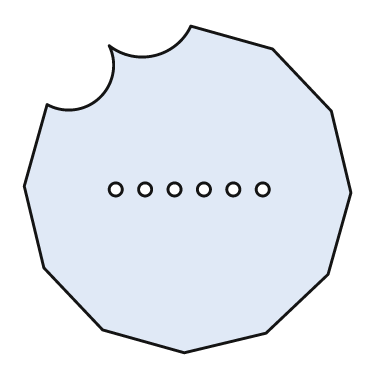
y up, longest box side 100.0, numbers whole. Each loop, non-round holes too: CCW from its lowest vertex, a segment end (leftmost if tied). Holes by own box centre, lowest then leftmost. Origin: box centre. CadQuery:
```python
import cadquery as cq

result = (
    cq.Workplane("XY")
    .moveTo(-1.0, -50.0)
    .lineTo(24.0, -44.0)
    .lineTo(43.0, -26.0)
    .lineTo(50.0, -1.0)
    .lineTo(44.0, 24.0)
    .lineTo(26.0, 43.0)
    .lineTo(1.0, 50.0)
    .threePointArc((-10.0, 41.0), (-24.0, 44.0))
    .threePointArc((-27.0, 28.0), (-43.0, 26.0))
    .lineTo(-50.0, 1.0)
    .lineTo(-44.0, -24.0)
    .lineTo(-26.0, -43.0)
    .close()
    .moveTo(-22.0, 0.0)
    .circle(2.0)
    .moveTo(-13.0, 0.0)
    .circle(2.0)
    .moveTo(-4.0, 0.0)
    .circle(2.0)
    .moveTo(5.0, 0.0)
    .circle(2.0)
    .moveTo(14.0, 0.0)
    .circle(2.0)
    .moveTo(23.0, 0.0)
    .circle(2.0)
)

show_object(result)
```